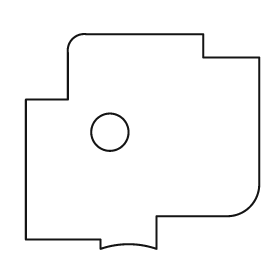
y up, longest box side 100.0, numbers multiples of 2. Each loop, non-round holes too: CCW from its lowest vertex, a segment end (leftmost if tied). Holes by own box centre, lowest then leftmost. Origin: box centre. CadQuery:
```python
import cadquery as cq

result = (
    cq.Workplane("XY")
    .moveTo(-18.0, -46.0)
    .threePointArc((-6.0, -44.0), (6.0, -46.0))
    .lineTo(6.0, -32.0)
    .lineTo(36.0, -32.0)
    .threePointArc((46.0, -28.0), (50.0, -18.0))
    .lineTo(50.0, 36.0)
    .lineTo(26.0, 36.0)
    .lineTo(26.0, 46.0)
    .lineTo(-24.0, 46.0)
    .threePointArc((-30.0, 44.0), (-32.0, 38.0))
    .lineTo(-32.0, 18.0)
    .lineTo(-50.0, 18.0)
    .lineTo(-50.0, -42.0)
    .lineTo(-18.0, -42.0)
    .close()
    .moveTo(-14.0, 4.0)
    .circle(8.0)
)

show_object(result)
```